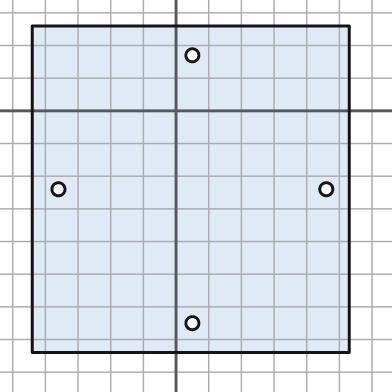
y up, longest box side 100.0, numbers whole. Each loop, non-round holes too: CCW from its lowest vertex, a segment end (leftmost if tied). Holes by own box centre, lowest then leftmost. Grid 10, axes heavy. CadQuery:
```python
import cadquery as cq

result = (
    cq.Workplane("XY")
    .moveTo(-44.0, -74.0)
    .lineTo(53.0, -74.0)
    .lineTo(53.0, 26.0)
    .lineTo(-44.0, 26.0)
    .close()
    .moveTo(5.0, -65.0)
    .circle(2.0)
    .moveTo(-36.0, -24.0)
    .circle(2.0)
    .moveTo(46.0, -24.0)
    .circle(2.0)
    .moveTo(5.0, 17.0)
    .circle(2.0)
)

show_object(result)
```